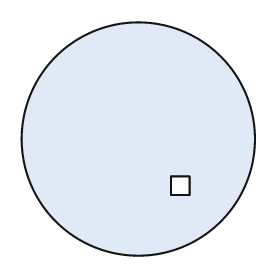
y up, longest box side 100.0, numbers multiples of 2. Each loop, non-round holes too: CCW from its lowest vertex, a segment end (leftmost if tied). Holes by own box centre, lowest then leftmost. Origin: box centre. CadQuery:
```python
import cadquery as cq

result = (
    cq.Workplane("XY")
    .moveTo(0.0, 0.0)
    .circle(50.0)
    .moveTo(14.0, -24.0)
    .lineTo(22.0, -24.0)
    .lineTo(22.0, -16.0)
    .lineTo(14.0, -16.0)
    .close()
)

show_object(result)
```